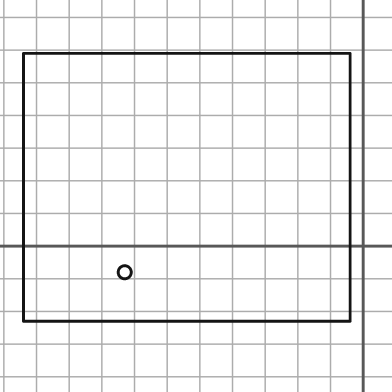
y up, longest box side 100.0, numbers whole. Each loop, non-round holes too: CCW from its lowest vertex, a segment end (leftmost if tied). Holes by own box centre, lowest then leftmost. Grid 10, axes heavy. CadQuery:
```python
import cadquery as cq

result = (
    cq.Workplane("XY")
    .moveTo(-104.0, -23.0)
    .lineTo(-4.0, -23.0)
    .lineTo(-4.0, 59.0)
    .lineTo(-104.0, 59.0)
    .close()
    .moveTo(-73.0, -8.0)
    .circle(2.0)
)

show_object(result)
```